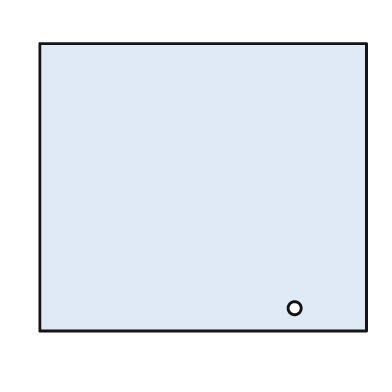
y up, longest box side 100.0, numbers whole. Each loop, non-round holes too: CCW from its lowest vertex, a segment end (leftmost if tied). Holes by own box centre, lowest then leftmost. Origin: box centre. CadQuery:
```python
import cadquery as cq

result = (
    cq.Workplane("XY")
    .moveTo(-50.0, -44.0)
    .lineTo(50.0, -44.0)
    .lineTo(50.0, 44.0)
    .lineTo(-50.0, 44.0)
    .close()
    .moveTo(28.0, -37.0)
    .circle(2.0)
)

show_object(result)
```